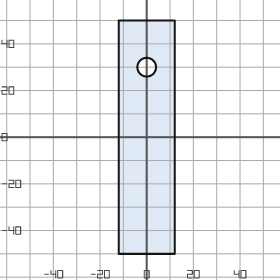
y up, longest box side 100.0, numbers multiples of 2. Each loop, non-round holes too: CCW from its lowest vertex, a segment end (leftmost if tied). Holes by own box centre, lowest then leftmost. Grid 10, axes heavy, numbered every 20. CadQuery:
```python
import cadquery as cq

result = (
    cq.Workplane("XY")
    .moveTo(-12.0, -50.0)
    .lineTo(12.0, -50.0)
    .lineTo(12.0, 50.0)
    .lineTo(-12.0, 50.0)
    .close()
    .moveTo(0.0, 30.0)
    .circle(4.0)
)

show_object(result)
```